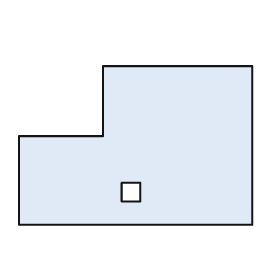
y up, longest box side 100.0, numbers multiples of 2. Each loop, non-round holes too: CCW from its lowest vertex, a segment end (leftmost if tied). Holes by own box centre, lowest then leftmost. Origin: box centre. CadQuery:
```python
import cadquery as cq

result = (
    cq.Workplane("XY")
    .moveTo(-50.0, -34.0)
    .lineTo(50.0, -34.0)
    .lineTo(50.0, 34.0)
    .lineTo(-14.0, 34.0)
    .lineTo(-14.0, 4.0)
    .lineTo(-50.0, 4.0)
    .close()
    .moveTo(-6.0, -24.0)
    .lineTo(2.0, -24.0)
    .lineTo(2.0, -16.0)
    .lineTo(-6.0, -16.0)
    .close()
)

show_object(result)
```